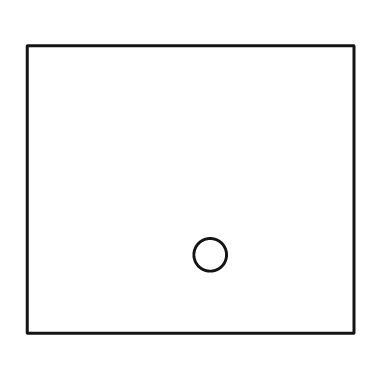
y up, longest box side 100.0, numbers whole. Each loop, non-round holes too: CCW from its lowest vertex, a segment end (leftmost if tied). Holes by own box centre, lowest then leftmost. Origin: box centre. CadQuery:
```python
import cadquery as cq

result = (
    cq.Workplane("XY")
    .moveTo(-50.0, -44.0)
    .lineTo(50.0, -44.0)
    .lineTo(50.0, 44.0)
    .lineTo(-50.0, 44.0)
    .close()
    .moveTo(6.0, -20.0)
    .circle(5.0)
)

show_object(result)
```